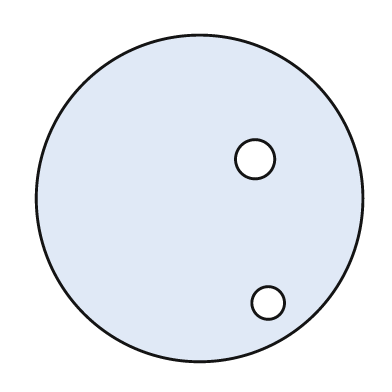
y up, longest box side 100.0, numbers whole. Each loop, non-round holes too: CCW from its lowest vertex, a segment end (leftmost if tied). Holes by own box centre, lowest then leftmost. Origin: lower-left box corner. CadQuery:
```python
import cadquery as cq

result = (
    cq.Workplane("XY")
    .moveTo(50.0, 50.0)
    .circle(50.0)
    .moveTo(71.0, 18.0)
    .circle(5.0)
    .moveTo(67.0, 62.0)
    .circle(6.0)
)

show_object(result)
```